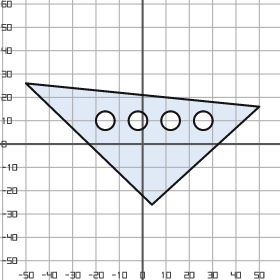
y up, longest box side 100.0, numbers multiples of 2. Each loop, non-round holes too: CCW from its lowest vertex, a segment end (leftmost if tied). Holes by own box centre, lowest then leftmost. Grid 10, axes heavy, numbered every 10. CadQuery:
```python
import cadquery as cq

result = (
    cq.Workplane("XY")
    .moveTo(4.0, -26.0)
    .lineTo(50.0, 16.0)
    .lineTo(-50.0, 26.0)
    .close()
    .moveTo(-16.0, 10.0)
    .circle(4.0)
    .moveTo(-2.0, 10.0)
    .circle(4.0)
    .moveTo(12.0, 10.0)
    .circle(4.0)
    .moveTo(26.0, 10.0)
    .circle(4.0)
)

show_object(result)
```